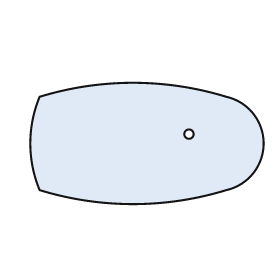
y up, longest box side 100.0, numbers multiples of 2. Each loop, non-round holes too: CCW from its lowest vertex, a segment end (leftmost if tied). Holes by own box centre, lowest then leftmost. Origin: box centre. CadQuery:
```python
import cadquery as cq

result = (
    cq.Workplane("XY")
    .moveTo(-46.0, -20.0)
    .threePointArc((-6.0, -26.0), (34.0, -20.0))
    .threePointArc((50.0, 0.0), (34.0, 20.0))
    .threePointArc((-6.0, 26.0), (-46.0, 20.0))
    .threePointArc((-50.0, 0.0), (-46.0, -20.0))
    .close()
    .moveTo(18.0, 4.0)
    .circle(2.0)
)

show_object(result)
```